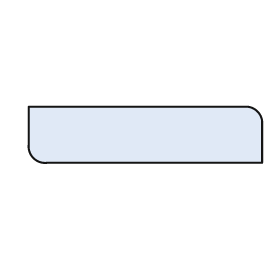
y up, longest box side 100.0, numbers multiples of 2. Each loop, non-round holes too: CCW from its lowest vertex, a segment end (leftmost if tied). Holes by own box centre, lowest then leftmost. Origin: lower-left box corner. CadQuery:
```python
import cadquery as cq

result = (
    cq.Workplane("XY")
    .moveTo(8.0, 0.0)
    .lineTo(100.0, 0.0)
    .lineTo(100.0, 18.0)
    .threePointArc((98.0, 22.0), (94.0, 24.0))
    .lineTo(0.0, 24.0)
    .lineTo(0.0, 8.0)
    .threePointArc((2.0, 2.0), (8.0, 0.0))
    .close()
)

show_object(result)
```